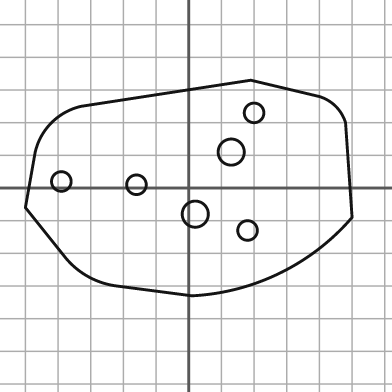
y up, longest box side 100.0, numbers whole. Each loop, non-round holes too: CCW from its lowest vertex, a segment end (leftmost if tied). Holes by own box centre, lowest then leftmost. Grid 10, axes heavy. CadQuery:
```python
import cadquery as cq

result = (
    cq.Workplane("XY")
    .moveTo(1.0, -33.0)
    .threePointArc((28.0, -26.0), (50.0, -9.0))
    .lineTo(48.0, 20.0)
    .threePointArc((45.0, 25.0), (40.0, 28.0))
    .lineTo(19.0, 33.0)
    .lineTo(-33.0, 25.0)
    .threePointArc((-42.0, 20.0), (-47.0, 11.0))
    .lineTo(-50.0, -6.0)
    .lineTo(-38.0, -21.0)
    .threePointArc((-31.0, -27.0), (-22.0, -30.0))
    .close()
    .moveTo(18.0, -13.0)
    .circle(3.0)
    .moveTo(2.0, -8.0)
    .circle(4.0)
    .moveTo(-16.0, 1.0)
    .circle(3.0)
    .moveTo(-39.0, 2.0)
    .circle(3.0)
    .moveTo(13.0, 11.0)
    .circle(4.0)
    .moveTo(20.0, 23.0)
    .circle(3.0)
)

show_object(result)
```